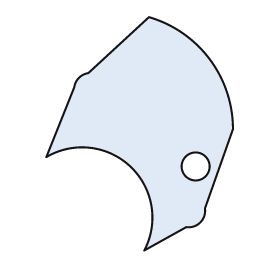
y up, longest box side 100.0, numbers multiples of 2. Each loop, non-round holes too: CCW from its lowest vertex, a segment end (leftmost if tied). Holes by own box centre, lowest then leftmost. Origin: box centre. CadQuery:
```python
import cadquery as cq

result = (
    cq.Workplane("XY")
    .moveTo(2.0, -50.0)
    .lineTo(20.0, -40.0)
    .threePointArc((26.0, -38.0), (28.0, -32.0))
    .lineTo(40.0, 2.0)
    .threePointArc((30.0, 32.0), (4.0, 50.0))
    .lineTo(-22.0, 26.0)
    .threePointArc((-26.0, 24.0), (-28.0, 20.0))
    .lineTo(-40.0, -10.0)
    .threePointArc((-4.0, -14.0), (2.0, -50.0))
    .close()
    .moveTo(24.0, -14.0)
    .circle(6.0)
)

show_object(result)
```